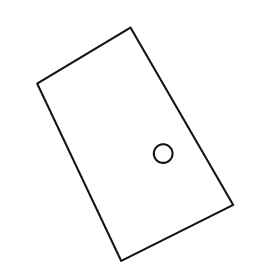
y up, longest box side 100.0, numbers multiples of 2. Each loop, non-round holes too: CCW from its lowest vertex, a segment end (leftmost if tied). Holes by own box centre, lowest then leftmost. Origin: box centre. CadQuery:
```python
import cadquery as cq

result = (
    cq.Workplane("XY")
    .moveTo(-6.0, -50.0)
    .lineTo(42.0, -26.0)
    .lineTo(-2.0, 50.0)
    .lineTo(-42.0, 26.0)
    .close()
    .moveTo(12.0, -4.0)
    .circle(4.0)
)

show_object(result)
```